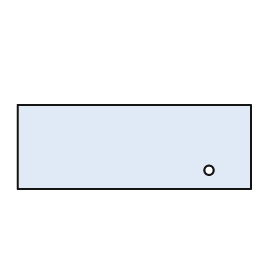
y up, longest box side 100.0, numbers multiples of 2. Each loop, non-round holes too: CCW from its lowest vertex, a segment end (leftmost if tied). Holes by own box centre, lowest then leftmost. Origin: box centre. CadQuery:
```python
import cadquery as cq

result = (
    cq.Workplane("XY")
    .moveTo(-50.0, -18.0)
    .lineTo(50.0, -18.0)
    .lineTo(50.0, 18.0)
    .lineTo(-50.0, 18.0)
    .close()
    .moveTo(32.0, -10.0)
    .circle(2.0)
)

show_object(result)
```